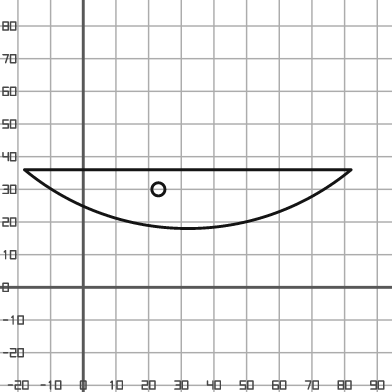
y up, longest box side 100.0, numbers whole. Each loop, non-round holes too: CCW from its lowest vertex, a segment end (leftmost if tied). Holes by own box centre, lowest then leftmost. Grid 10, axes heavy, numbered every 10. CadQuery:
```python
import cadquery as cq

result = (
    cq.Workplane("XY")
    .moveTo(-18.0, 36.0)
    .threePointArc((32.0, 18.0), (82.0, 36.0))
    .close()
    .moveTo(23.0, 30.0)
    .circle(2.0)
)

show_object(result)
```